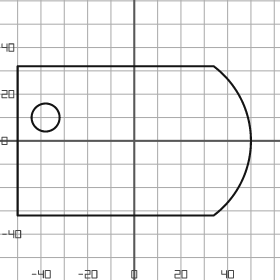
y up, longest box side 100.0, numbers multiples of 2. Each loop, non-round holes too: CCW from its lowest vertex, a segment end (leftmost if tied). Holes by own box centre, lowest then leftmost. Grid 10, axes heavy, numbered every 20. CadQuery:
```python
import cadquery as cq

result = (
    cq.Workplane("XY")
    .moveTo(-50.0, -32.0)
    .lineTo(34.0, -32.0)
    .threePointArc((50.0, 0.0), (34.0, 32.0))
    .lineTo(-50.0, 32.0)
    .close()
    .moveTo(-38.0, 10.0)
    .circle(6.0)
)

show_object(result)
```